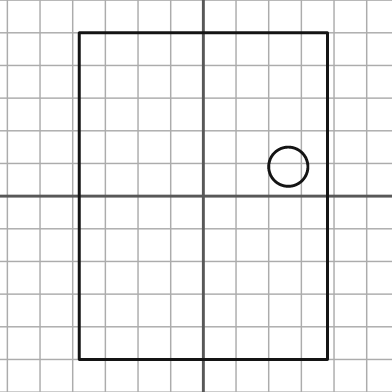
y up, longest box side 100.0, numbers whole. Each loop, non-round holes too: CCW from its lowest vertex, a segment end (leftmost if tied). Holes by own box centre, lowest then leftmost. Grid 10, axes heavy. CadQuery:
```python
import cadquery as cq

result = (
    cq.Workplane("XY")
    .moveTo(-38.0, -50.0)
    .lineTo(38.0, -50.0)
    .lineTo(38.0, 50.0)
    .lineTo(-38.0, 50.0)
    .close()
    .moveTo(26.0, 9.0)
    .circle(6.0)
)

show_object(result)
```